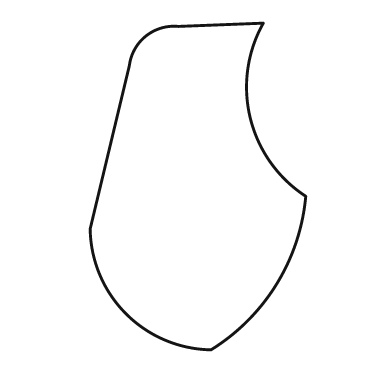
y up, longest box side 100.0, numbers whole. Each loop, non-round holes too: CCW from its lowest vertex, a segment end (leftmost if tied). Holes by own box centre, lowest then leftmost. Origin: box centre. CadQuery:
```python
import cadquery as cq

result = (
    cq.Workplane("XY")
    .moveTo(4.0, -50.0)
    .threePointArc((24.0, -30.0), (33.0, -3.0))
    .threePointArc((16.0, 21.0), (20.0, 50.0))
    .lineTo(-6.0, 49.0)
    .threePointArc((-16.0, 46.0), (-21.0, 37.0))
    .lineTo(-33.0, -13.0)
    .threePointArc((-22.0, -39.0), (4.0, -50.0))
    .close()
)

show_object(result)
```